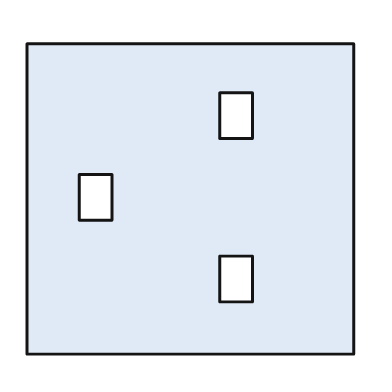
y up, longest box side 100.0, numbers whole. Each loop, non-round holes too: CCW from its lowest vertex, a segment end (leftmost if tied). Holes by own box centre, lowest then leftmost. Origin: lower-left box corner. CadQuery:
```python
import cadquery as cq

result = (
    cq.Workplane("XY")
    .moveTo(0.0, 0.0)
    .lineTo(100.0, 0.0)
    .lineTo(100.0, 95.0)
    .lineTo(0.0, 95.0)
    .close()
    .moveTo(59.0, 16.0)
    .lineTo(69.0, 16.0)
    .lineTo(69.0, 30.0)
    .lineTo(59.0, 30.0)
    .close()
    .moveTo(16.0, 41.0)
    .lineTo(26.0, 41.0)
    .lineTo(26.0, 55.0)
    .lineTo(16.0, 55.0)
    .close()
    .moveTo(59.0, 66.0)
    .lineTo(69.0, 66.0)
    .lineTo(69.0, 80.0)
    .lineTo(59.0, 80.0)
    .close()
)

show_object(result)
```